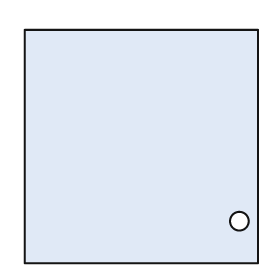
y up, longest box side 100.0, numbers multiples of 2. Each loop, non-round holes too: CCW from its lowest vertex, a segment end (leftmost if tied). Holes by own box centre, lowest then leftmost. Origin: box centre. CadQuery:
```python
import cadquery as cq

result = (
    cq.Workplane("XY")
    .moveTo(-50.0, -50.0)
    .lineTo(50.0, -50.0)
    .lineTo(50.0, 50.0)
    .lineTo(-50.0, 50.0)
    .close()
    .moveTo(42.0, -32.0)
    .circle(4.0)
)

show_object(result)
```